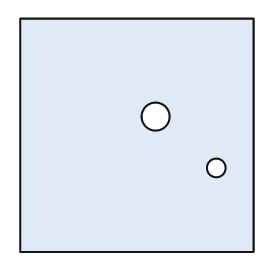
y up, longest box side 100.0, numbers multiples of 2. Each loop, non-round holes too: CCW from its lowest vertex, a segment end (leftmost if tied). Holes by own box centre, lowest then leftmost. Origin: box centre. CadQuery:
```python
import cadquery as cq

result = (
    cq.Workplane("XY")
    .moveTo(-50.0, -50.0)
    .lineTo(50.0, -50.0)
    .lineTo(50.0, 50.0)
    .lineTo(-50.0, 50.0)
    .close()
    .moveTo(34.0, -14.0)
    .circle(4.0)
    .moveTo(8.0, 8.0)
    .circle(6.0)
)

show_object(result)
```